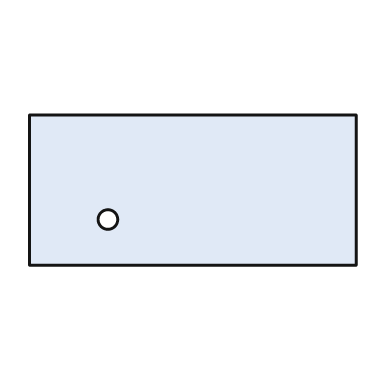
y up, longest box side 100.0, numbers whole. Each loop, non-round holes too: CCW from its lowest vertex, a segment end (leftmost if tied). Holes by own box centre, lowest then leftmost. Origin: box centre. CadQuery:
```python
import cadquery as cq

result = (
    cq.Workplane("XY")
    .moveTo(-50.0, -23.0)
    .lineTo(50.0, -23.0)
    .lineTo(50.0, 23.0)
    .lineTo(-50.0, 23.0)
    .close()
    .moveTo(-26.0, -9.0)
    .circle(3.0)
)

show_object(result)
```